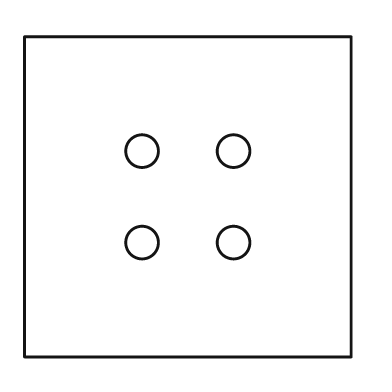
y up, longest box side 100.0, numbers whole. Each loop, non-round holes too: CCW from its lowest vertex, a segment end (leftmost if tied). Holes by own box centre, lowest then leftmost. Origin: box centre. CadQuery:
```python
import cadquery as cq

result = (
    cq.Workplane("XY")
    .moveTo(-50.0, -49.0)
    .lineTo(50.0, -49.0)
    .lineTo(50.0, 49.0)
    .lineTo(-50.0, 49.0)
    .close()
    .moveTo(-14.0, -14.0)
    .circle(5.0)
    .moveTo(14.0, -14.0)
    .circle(5.0)
    .moveTo(-14.0, 14.0)
    .circle(5.0)
    .moveTo(14.0, 14.0)
    .circle(5.0)
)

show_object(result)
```